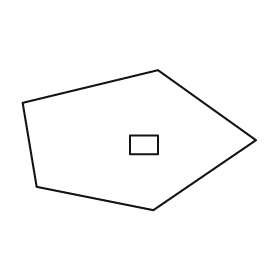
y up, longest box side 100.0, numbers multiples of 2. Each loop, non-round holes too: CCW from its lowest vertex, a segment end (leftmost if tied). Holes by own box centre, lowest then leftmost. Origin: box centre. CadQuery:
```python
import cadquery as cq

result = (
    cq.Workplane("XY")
    .moveTo(6.0, -30.0)
    .lineTo(50.0, 0.0)
    .lineTo(8.0, 30.0)
    .lineTo(-50.0, 16.0)
    .lineTo(-44.0, -20.0)
    .close()
    .moveTo(-4.0, -6.0)
    .lineTo(8.0, -6.0)
    .lineTo(8.0, 2.0)
    .lineTo(-4.0, 2.0)
    .close()
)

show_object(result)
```